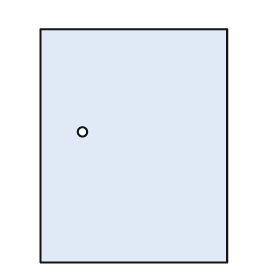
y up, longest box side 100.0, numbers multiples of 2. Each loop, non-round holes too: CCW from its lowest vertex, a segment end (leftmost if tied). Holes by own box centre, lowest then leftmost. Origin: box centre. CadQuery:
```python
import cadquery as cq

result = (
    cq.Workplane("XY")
    .moveTo(-40.0, -50.0)
    .lineTo(40.0, -50.0)
    .lineTo(40.0, 50.0)
    .lineTo(-40.0, 50.0)
    .close()
    .moveTo(-22.0, 6.0)
    .circle(2.0)
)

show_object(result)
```